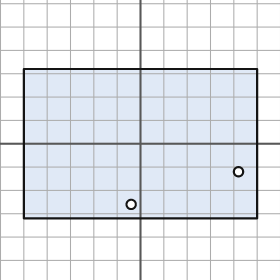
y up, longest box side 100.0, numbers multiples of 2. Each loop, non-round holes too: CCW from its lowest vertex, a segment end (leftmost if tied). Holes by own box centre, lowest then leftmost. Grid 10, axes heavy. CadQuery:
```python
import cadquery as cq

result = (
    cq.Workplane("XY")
    .moveTo(-50.0, -32.0)
    .lineTo(50.0, -32.0)
    .lineTo(50.0, 32.0)
    .lineTo(-50.0, 32.0)
    .close()
    .moveTo(-4.0, -26.0)
    .circle(2.0)
    .moveTo(42.0, -12.0)
    .circle(2.0)
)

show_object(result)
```